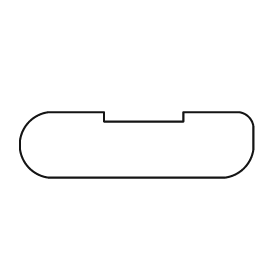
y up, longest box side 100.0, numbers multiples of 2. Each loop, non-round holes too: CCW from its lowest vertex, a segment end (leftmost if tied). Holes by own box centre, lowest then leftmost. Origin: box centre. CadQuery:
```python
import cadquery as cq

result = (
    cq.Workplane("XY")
    .moveTo(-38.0, -14.0)
    .lineTo(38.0, -14.0)
    .threePointArc((46.0, -10.0), (50.0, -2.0))
    .lineTo(50.0, 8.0)
    .threePointArc((48.0, 12.0), (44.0, 14.0))
    .lineTo(20.0, 14.0)
    .lineTo(20.0, 10.0)
    .lineTo(-14.0, 10.0)
    .lineTo(-14.0, 14.0)
    .lineTo(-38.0, 14.0)
    .threePointArc((-46.0, 10.0), (-50.0, 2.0))
    .lineTo(-50.0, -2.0)
    .threePointArc((-46.0, -10.0), (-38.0, -14.0))
    .close()
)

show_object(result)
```